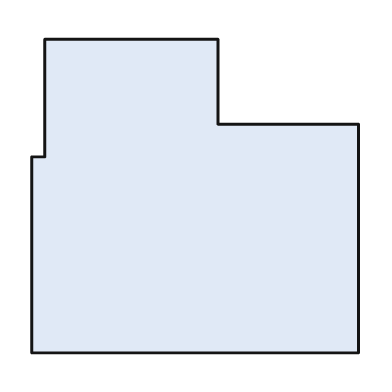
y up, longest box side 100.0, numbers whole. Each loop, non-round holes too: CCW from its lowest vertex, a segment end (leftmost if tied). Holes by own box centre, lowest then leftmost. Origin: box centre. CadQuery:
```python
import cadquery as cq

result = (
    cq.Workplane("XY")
    .moveTo(-50.0, -48.0)
    .lineTo(50.0, -48.0)
    .lineTo(50.0, 22.0)
    .lineTo(7.0, 22.0)
    .lineTo(7.0, 48.0)
    .lineTo(-46.0, 48.0)
    .lineTo(-46.0, 12.0)
    .lineTo(-50.0, 12.0)
    .close()
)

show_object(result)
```